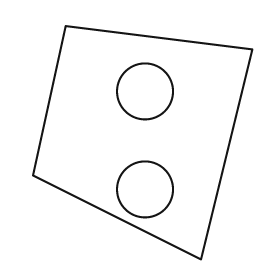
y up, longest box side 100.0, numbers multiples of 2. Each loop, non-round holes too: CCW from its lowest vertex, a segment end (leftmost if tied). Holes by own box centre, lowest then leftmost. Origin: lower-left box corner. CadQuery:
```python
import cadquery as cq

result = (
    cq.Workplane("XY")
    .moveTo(72.0, 0.0)
    .lineTo(94.0, 90.0)
    .lineTo(14.0, 100.0)
    .lineTo(0.0, 36.0)
    .close()
    .moveTo(48.0, 30.0)
    .circle(12.0)
    .moveTo(48.0, 72.0)
    .circle(12.0)
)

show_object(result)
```